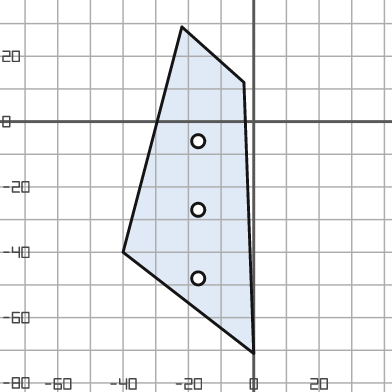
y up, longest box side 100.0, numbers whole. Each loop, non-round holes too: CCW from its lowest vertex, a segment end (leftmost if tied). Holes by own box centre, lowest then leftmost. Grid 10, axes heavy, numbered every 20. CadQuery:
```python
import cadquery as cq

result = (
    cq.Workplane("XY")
    .moveTo(0.0, -71.0)
    .lineTo(-3.0, 12.0)
    .lineTo(-22.0, 29.0)
    .lineTo(-40.0, -40.0)
    .close()
    .moveTo(-17.0, -48.0)
    .circle(2.0)
    .moveTo(-17.0, -27.0)
    .circle(2.0)
    .moveTo(-17.0, -6.0)
    .circle(2.0)
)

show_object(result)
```